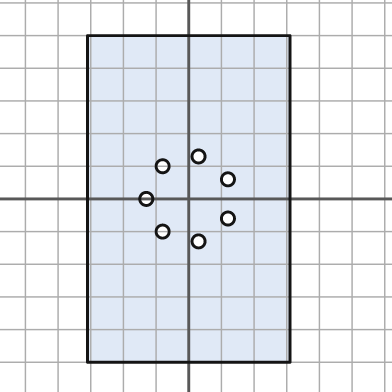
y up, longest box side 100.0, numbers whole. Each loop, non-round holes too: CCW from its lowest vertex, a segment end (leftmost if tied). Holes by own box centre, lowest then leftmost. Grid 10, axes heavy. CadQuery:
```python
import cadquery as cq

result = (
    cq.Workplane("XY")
    .moveTo(-31.0, -50.0)
    .lineTo(31.0, -50.0)
    .lineTo(31.0, 50.0)
    .lineTo(-31.0, 50.0)
    .close()
    .moveTo(3.0, -13.0)
    .circle(2.0)
    .moveTo(-8.0, -10.0)
    .circle(2.0)
    .moveTo(12.0, -6.0)
    .circle(2.0)
    .moveTo(-13.0, 0.0)
    .circle(2.0)
    .moveTo(12.0, 6.0)
    .circle(2.0)
    .moveTo(-8.0, 10.0)
    .circle(2.0)
    .moveTo(3.0, 13.0)
    .circle(2.0)
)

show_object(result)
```